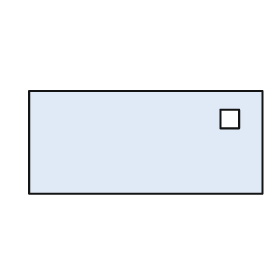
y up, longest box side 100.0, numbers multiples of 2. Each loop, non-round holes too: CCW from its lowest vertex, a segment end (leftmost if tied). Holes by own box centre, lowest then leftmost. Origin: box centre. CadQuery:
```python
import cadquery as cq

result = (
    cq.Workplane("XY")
    .moveTo(-50.0, -22.0)
    .lineTo(50.0, -22.0)
    .lineTo(50.0, 22.0)
    .lineTo(-50.0, 22.0)
    .close()
    .moveTo(32.0, 6.0)
    .lineTo(40.0, 6.0)
    .lineTo(40.0, 14.0)
    .lineTo(32.0, 14.0)
    .close()
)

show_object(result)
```